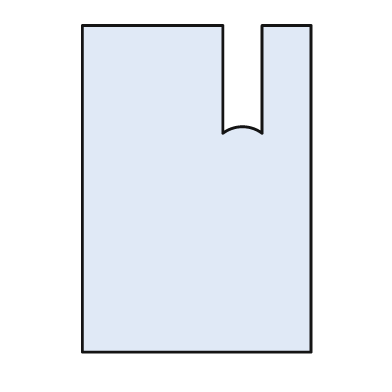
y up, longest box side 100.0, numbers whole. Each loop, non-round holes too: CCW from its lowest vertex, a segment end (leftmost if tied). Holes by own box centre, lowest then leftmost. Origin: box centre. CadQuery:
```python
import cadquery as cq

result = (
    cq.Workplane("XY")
    .moveTo(-35.0, -50.0)
    .lineTo(35.0, -50.0)
    .lineTo(35.0, 50.0)
    .lineTo(20.0, 50.0)
    .lineTo(20.0, 17.0)
    .threePointArc((14.0, 19.0), (8.0, 17.0))
    .lineTo(8.0, 50.0)
    .lineTo(-35.0, 50.0)
    .close()
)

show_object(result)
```